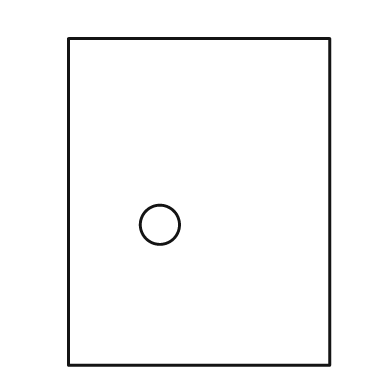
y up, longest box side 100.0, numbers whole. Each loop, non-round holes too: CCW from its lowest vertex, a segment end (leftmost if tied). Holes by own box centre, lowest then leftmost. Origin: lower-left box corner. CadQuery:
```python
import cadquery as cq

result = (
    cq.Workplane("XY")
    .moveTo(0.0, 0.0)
    .lineTo(80.0, 0.0)
    .lineTo(80.0, 100.0)
    .lineTo(0.0, 100.0)
    .close()
    .moveTo(28.0, 43.0)
    .circle(6.0)
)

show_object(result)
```